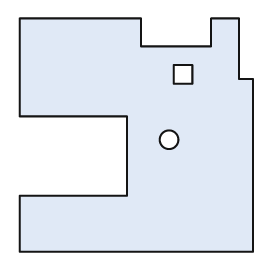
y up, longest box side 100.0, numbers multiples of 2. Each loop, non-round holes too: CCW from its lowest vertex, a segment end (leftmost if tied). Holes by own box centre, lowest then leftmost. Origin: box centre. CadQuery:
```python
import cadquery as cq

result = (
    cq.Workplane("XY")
    .moveTo(-50.0, -50.0)
    .lineTo(50.0, -50.0)
    .lineTo(50.0, 24.0)
    .lineTo(44.0, 24.0)
    .lineTo(44.0, 50.0)
    .lineTo(32.0, 50.0)
    .lineTo(32.0, 38.0)
    .lineTo(2.0, 38.0)
    .lineTo(2.0, 50.0)
    .lineTo(-50.0, 50.0)
    .lineTo(-50.0, 8.0)
    .lineTo(-4.0, 8.0)
    .lineTo(-4.0, -26.0)
    .lineTo(-50.0, -26.0)
    .close()
    .moveTo(14.0, -2.0)
    .circle(4.0)
    .moveTo(16.0, 22.0)
    .lineTo(24.0, 22.0)
    .lineTo(24.0, 30.0)
    .lineTo(16.0, 30.0)
    .close()
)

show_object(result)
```